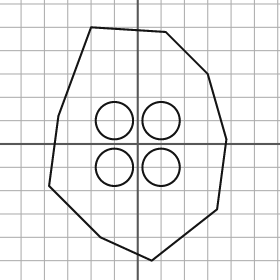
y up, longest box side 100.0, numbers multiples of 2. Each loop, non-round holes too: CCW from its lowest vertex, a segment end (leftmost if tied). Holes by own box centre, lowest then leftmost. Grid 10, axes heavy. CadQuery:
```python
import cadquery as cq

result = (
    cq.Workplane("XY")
    .moveTo(6.0, -50.0)
    .lineTo(34.0, -28.0)
    .lineTo(38.0, 2.0)
    .lineTo(30.0, 30.0)
    .lineTo(12.0, 48.0)
    .lineTo(-20.0, 50.0)
    .lineTo(-34.0, 12.0)
    .lineTo(-38.0, -18.0)
    .lineTo(-16.0, -40.0)
    .close()
    .moveTo(-10.0, -10.0)
    .circle(8.0)
    .moveTo(10.0, -10.0)
    .circle(8.0)
    .moveTo(-10.0, 10.0)
    .circle(8.0)
    .moveTo(10.0, 10.0)
    .circle(8.0)
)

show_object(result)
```